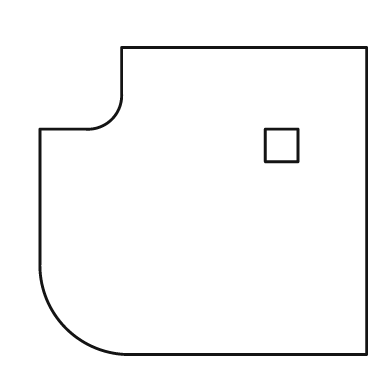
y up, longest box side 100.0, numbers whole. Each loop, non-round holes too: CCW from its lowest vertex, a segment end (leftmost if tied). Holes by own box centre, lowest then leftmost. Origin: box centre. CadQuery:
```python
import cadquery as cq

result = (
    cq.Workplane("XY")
    .moveTo(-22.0, -47.0)
    .lineTo(50.0, -47.0)
    .lineTo(50.0, 47.0)
    .lineTo(-25.0, 47.0)
    .lineTo(-25.0, 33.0)
    .threePointArc((-28.0, 25.0), (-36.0, 22.0))
    .lineTo(-50.0, 22.0)
    .lineTo(-50.0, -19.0)
    .threePointArc((-42.0, -39.0), (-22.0, -47.0))
    .close()
    .moveTo(19.0, 12.0)
    .lineTo(29.0, 12.0)
    .lineTo(29.0, 22.0)
    .lineTo(19.0, 22.0)
    .close()
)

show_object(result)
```